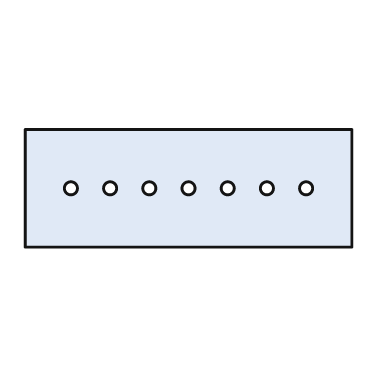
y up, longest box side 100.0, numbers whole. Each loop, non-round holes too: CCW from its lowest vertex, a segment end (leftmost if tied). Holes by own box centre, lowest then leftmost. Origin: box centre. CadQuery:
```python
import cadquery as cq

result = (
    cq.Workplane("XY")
    .moveTo(-50.0, -18.0)
    .lineTo(50.0, -18.0)
    .lineTo(50.0, 18.0)
    .lineTo(-50.0, 18.0)
    .close()
    .moveTo(-36.0, 0.0)
    .circle(2.0)
    .moveTo(-24.0, 0.0)
    .circle(2.0)
    .moveTo(-12.0, 0.0)
    .circle(2.0)
    .moveTo(0.0, 0.0)
    .circle(2.0)
    .moveTo(12.0, 0.0)
    .circle(2.0)
    .moveTo(24.0, 0.0)
    .circle(2.0)
    .moveTo(36.0, 0.0)
    .circle(2.0)
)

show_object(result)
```